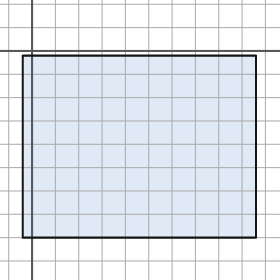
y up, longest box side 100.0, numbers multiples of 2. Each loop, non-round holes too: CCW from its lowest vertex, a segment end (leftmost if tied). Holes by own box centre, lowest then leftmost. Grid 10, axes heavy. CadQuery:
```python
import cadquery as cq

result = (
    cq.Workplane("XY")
    .moveTo(-4.0, -80.0)
    .lineTo(96.0, -80.0)
    .lineTo(96.0, -2.0)
    .lineTo(-4.0, -2.0)
    .close()
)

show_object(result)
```